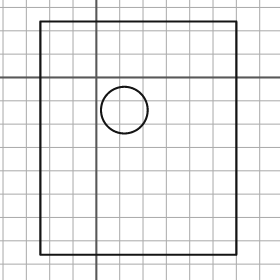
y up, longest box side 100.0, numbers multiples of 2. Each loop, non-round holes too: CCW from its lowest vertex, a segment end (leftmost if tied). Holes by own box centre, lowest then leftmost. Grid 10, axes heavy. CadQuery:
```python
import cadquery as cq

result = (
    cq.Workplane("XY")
    .moveTo(-24.0, -76.0)
    .lineTo(60.0, -76.0)
    .lineTo(60.0, 24.0)
    .lineTo(-24.0, 24.0)
    .close()
    .moveTo(12.0, -14.0)
    .circle(10.0)
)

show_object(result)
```